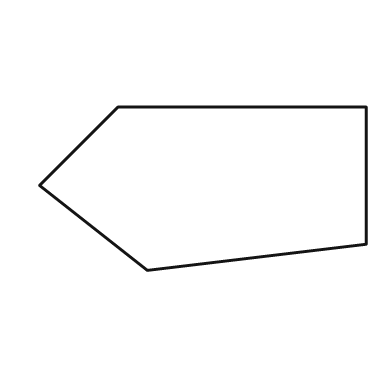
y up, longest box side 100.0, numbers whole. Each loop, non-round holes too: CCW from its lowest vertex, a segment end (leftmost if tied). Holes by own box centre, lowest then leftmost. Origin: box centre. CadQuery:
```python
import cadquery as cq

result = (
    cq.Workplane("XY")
    .moveTo(-17.0, -25.0)
    .lineTo(50.0, -17.0)
    .lineTo(50.0, 25.0)
    .lineTo(-26.0, 25.0)
    .lineTo(-50.0, 1.0)
    .close()
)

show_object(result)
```